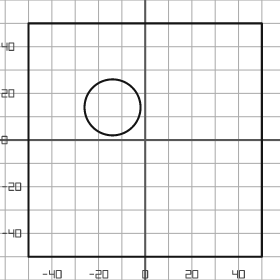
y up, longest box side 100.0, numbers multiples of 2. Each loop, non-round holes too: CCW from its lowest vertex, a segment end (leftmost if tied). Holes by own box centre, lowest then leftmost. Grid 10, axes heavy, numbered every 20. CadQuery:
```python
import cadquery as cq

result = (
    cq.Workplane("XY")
    .moveTo(-50.0, -50.0)
    .lineTo(50.0, -50.0)
    .lineTo(50.0, 50.0)
    .lineTo(-50.0, 50.0)
    .close()
    .moveTo(-14.0, 14.0)
    .circle(12.0)
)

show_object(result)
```